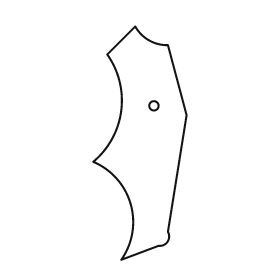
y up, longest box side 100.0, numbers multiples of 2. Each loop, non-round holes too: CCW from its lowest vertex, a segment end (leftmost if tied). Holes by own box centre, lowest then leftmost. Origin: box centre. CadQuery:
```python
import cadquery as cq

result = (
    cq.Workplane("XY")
    .moveTo(-8.0, -50.0)
    .lineTo(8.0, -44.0)
    .threePointArc((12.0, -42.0), (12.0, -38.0))
    .lineTo(20.0, 12.0)
    .lineTo(12.0, 42.0)
    .threePointArc((4.0, 44.0), (-2.0, 50.0))
    .lineTo(-14.0, 38.0)
    .threePointArc((-8.0, 14.0), (-20.0, -8.0))
    .threePointArc((-4.0, -26.0), (-8.0, -50.0))
    .close()
    .moveTo(6.0, 16.0)
    .circle(2.0)
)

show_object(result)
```